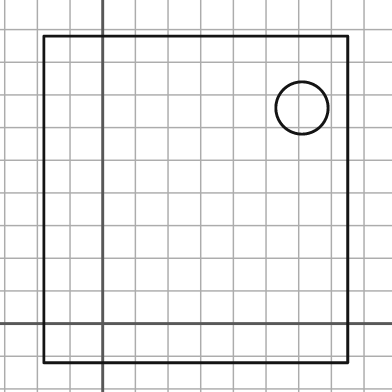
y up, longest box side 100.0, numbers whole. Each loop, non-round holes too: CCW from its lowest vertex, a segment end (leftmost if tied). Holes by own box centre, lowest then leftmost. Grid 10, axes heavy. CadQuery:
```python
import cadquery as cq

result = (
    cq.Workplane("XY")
    .moveTo(-18.0, -12.0)
    .lineTo(75.0, -12.0)
    .lineTo(75.0, 88.0)
    .lineTo(-18.0, 88.0)
    .close()
    .moveTo(61.0, 66.0)
    .circle(8.0)
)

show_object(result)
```